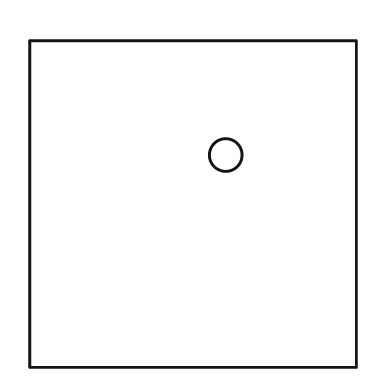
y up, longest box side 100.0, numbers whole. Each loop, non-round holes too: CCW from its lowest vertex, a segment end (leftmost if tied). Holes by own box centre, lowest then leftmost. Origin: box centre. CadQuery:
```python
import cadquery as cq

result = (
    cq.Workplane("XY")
    .moveTo(-50.0, -50.0)
    .lineTo(50.0, -50.0)
    .lineTo(50.0, 50.0)
    .lineTo(-50.0, 50.0)
    .close()
    .moveTo(10.0, 15.0)
    .circle(5.0)
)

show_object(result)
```